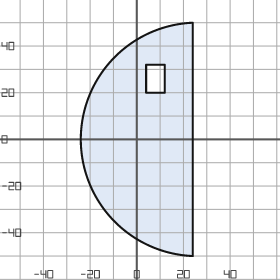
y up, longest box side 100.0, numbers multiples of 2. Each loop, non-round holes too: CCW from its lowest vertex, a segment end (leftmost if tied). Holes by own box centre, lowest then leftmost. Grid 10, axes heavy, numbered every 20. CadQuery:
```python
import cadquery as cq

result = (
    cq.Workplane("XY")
    .moveTo(24.0, -50.0)
    .lineTo(24.0, 50.0)
    .threePointArc((-24.0, 0.0), (24.0, -50.0))
    .close()
    .moveTo(4.0, 20.0)
    .lineTo(12.0, 20.0)
    .lineTo(12.0, 32.0)
    .lineTo(4.0, 32.0)
    .close()
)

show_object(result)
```